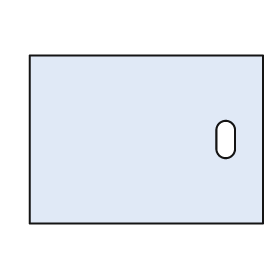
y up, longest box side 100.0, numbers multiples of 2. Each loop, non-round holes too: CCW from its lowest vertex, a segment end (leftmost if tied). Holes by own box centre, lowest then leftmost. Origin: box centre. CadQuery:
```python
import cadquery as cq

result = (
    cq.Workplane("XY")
    .moveTo(-50.0, -36.0)
    .lineTo(50.0, -36.0)
    .lineTo(50.0, 36.0)
    .lineTo(-50.0, 36.0)
    .close()
    .moveTo(30.0, -4.0)
    .threePointArc((34.0, -8.0), (38.0, -4.0))
    .lineTo(38.0, 4.0)
    .threePointArc((34.0, 8.0), (30.0, 4.0))
    .close()
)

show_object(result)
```